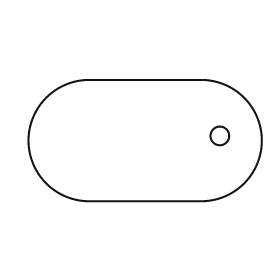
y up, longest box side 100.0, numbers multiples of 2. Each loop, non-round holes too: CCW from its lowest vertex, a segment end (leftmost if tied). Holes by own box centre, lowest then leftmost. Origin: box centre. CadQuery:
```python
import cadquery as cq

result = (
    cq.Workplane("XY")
    .moveTo(-24.0, -26.0)
    .lineTo(24.0, -26.0)
    .threePointArc((50.0, 0.0), (24.0, 26.0))
    .lineTo(-24.0, 26.0)
    .threePointArc((-50.0, 0.0), (-24.0, -26.0))
    .close()
    .moveTo(32.0, 2.0)
    .circle(4.0)
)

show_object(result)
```